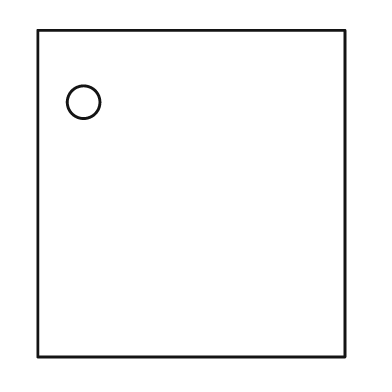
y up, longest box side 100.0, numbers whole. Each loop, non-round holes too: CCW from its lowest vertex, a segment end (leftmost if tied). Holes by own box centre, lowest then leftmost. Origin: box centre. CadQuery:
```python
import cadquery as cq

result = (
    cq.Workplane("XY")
    .moveTo(-47.0, -50.0)
    .lineTo(47.0, -50.0)
    .lineTo(47.0, 50.0)
    .lineTo(-47.0, 50.0)
    .close()
    .moveTo(-33.0, 28.0)
    .circle(5.0)
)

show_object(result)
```